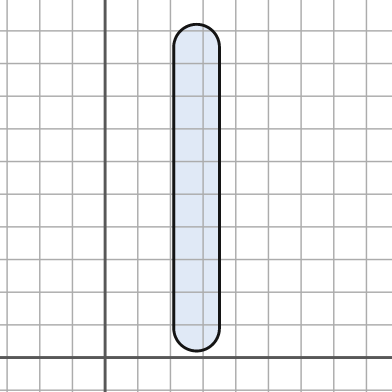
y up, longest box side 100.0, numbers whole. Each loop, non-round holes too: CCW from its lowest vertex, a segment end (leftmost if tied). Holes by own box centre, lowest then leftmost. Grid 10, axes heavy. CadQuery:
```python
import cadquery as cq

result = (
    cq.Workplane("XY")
    .moveTo(21.0, 9.0)
    .threePointArc((28.0, 2.0), (35.0, 9.0))
    .lineTo(35.0, 95.0)
    .threePointArc((28.0, 102.0), (21.0, 95.0))
    .close()
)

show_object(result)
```